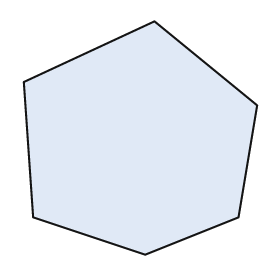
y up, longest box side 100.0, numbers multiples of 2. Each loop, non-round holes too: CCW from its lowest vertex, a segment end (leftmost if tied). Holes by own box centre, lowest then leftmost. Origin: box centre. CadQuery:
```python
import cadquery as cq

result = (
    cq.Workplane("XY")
    .moveTo(2.0, -50.0)
    .lineTo(42.0, -34.0)
    .lineTo(50.0, 14.0)
    .lineTo(6.0, 50.0)
    .lineTo(-50.0, 24.0)
    .lineTo(-46.0, -34.0)
    .close()
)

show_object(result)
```